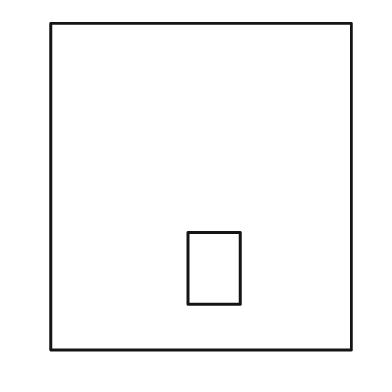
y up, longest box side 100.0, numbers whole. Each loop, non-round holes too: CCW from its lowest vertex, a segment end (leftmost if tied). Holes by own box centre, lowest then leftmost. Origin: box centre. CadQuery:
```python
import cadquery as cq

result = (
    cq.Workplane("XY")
    .moveTo(-46.0, -50.0)
    .lineTo(46.0, -50.0)
    .lineTo(46.0, 50.0)
    .lineTo(-46.0, 50.0)
    .close()
    .moveTo(-4.0, -36.0)
    .lineTo(12.0, -36.0)
    .lineTo(12.0, -14.0)
    .lineTo(-4.0, -14.0)
    .close()
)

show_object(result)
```